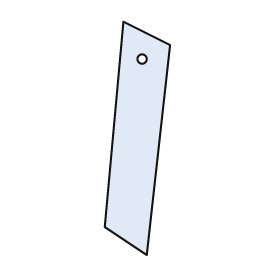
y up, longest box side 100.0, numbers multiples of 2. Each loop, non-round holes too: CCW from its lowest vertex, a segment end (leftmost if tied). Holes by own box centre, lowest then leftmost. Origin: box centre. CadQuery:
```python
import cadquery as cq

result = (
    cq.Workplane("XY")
    .moveTo(4.0, -50.0)
    .lineTo(14.0, 40.0)
    .lineTo(-6.0, 50.0)
    .lineTo(-14.0, -38.0)
    .close()
    .moveTo(2.0, 34.0)
    .circle(2.0)
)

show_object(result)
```